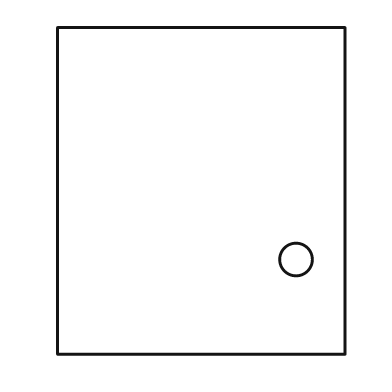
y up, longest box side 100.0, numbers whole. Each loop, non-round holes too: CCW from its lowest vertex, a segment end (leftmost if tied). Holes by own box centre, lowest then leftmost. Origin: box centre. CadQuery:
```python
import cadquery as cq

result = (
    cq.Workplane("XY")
    .moveTo(-44.0, -50.0)
    .lineTo(44.0, -50.0)
    .lineTo(44.0, 50.0)
    .lineTo(-44.0, 50.0)
    .close()
    .moveTo(29.0, -21.0)
    .circle(5.0)
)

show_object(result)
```